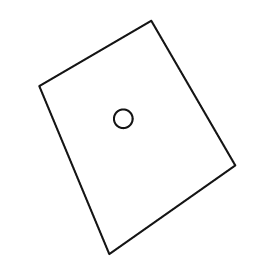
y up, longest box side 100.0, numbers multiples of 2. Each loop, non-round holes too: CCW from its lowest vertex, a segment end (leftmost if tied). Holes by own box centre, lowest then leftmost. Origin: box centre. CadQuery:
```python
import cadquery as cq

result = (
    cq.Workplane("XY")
    .moveTo(-12.0, -50.0)
    .lineTo(42.0, -12.0)
    .lineTo(6.0, 50.0)
    .lineTo(-42.0, 22.0)
    .close()
    .moveTo(-6.0, 8.0)
    .circle(4.0)
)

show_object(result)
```